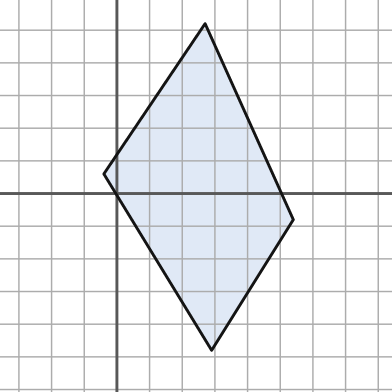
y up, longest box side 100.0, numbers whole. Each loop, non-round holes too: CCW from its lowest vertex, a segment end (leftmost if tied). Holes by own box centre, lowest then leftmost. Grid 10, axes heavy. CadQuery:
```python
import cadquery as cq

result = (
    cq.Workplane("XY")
    .moveTo(29.0, -48.0)
    .lineTo(54.0, -8.0)
    .lineTo(27.0, 52.0)
    .lineTo(-4.0, 6.0)
    .close()
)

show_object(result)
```